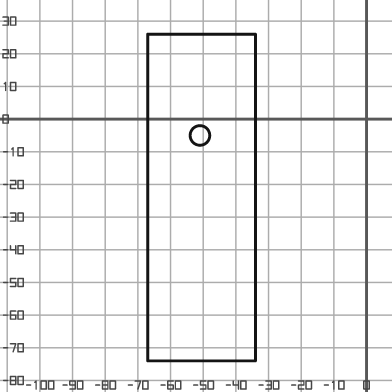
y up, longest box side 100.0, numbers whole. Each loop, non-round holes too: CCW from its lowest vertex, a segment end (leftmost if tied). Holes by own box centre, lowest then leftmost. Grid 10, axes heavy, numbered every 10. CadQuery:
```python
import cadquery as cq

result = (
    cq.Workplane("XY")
    .moveTo(-67.0, -74.0)
    .lineTo(-34.0, -74.0)
    .lineTo(-34.0, 26.0)
    .lineTo(-67.0, 26.0)
    .close()
    .moveTo(-51.0, -5.0)
    .circle(3.0)
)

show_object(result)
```